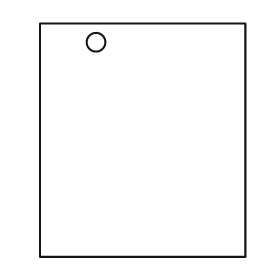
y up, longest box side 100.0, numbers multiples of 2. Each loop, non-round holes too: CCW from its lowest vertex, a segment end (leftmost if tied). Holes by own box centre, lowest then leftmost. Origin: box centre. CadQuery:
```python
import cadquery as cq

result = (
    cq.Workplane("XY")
    .moveTo(-44.0, -50.0)
    .lineTo(44.0, -50.0)
    .lineTo(44.0, 50.0)
    .lineTo(-44.0, 50.0)
    .close()
    .moveTo(-20.0, 42.0)
    .circle(4.0)
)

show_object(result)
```